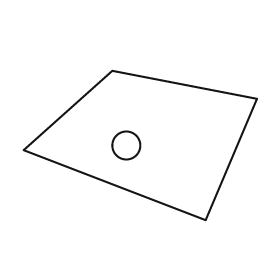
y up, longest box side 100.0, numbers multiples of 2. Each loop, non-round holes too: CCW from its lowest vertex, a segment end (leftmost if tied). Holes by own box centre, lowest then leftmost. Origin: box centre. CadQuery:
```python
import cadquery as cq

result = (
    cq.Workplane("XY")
    .moveTo(28.0, -32.0)
    .lineTo(50.0, 20.0)
    .lineTo(-12.0, 32.0)
    .lineTo(-50.0, -2.0)
    .close()
    .moveTo(-6.0, 0.0)
    .circle(6.0)
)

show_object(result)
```